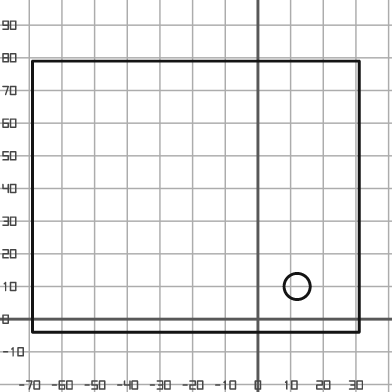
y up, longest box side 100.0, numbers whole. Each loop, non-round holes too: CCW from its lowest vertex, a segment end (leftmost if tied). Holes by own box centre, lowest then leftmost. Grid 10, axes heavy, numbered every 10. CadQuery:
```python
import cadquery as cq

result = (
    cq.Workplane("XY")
    .moveTo(-69.0, -4.0)
    .lineTo(31.0, -4.0)
    .lineTo(31.0, 79.0)
    .lineTo(-69.0, 79.0)
    .close()
    .moveTo(12.0, 10.0)
    .circle(4.0)
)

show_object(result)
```